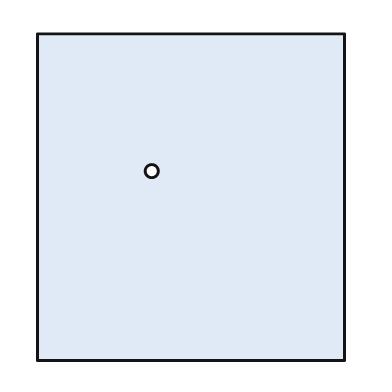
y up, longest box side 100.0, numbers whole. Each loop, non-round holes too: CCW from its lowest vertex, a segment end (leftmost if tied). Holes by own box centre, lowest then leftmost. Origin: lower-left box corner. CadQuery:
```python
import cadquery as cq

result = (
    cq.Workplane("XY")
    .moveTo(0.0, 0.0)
    .lineTo(94.0, 0.0)
    .lineTo(94.0, 100.0)
    .lineTo(0.0, 100.0)
    .close()
    .moveTo(35.0, 58.0)
    .circle(2.0)
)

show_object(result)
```